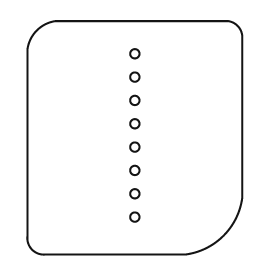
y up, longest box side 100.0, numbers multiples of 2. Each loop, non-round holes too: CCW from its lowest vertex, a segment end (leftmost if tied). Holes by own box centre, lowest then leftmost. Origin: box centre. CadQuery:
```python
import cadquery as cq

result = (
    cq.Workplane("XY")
    .moveTo(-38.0, -50.0)
    .lineTo(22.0, -50.0)
    .threePointArc((38.0, -42.0), (46.0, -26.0))
    .lineTo(46.0, 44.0)
    .threePointArc((44.0, 48.0), (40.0, 50.0))
    .lineTo(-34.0, 50.0)
    .threePointArc((-42.0, 46.0), (-46.0, 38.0))
    .lineTo(-46.0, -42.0)
    .threePointArc((-44.0, -48.0), (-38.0, -50.0))
    .close()
    .moveTo(0.0, -34.0)
    .circle(2.0)
    .moveTo(0.0, -24.0)
    .circle(2.0)
    .moveTo(0.0, -14.0)
    .circle(2.0)
    .moveTo(0.0, -4.0)
    .circle(2.0)
    .moveTo(0.0, 6.0)
    .circle(2.0)
    .moveTo(0.0, 16.0)
    .circle(2.0)
    .moveTo(0.0, 26.0)
    .circle(2.0)
    .moveTo(0.0, 36.0)
    .circle(2.0)
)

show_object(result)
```